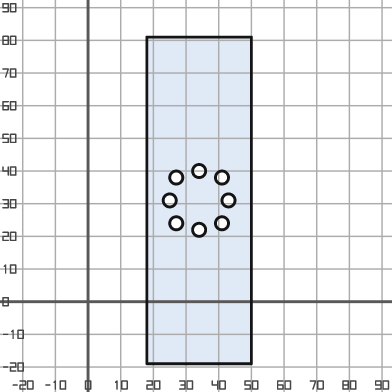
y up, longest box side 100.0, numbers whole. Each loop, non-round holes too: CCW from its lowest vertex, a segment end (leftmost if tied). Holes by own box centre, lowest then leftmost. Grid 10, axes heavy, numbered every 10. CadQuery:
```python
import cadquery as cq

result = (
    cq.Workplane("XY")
    .moveTo(18.0, -19.0)
    .lineTo(50.0, -19.0)
    .lineTo(50.0, 81.0)
    .lineTo(18.0, 81.0)
    .close()
    .moveTo(34.0, 22.0)
    .circle(2.0)
    .moveTo(27.0, 24.0)
    .circle(2.0)
    .moveTo(41.0, 24.0)
    .circle(2.0)
    .moveTo(25.0, 31.0)
    .circle(2.0)
    .moveTo(43.0, 31.0)
    .circle(2.0)
    .moveTo(27.0, 38.0)
    .circle(2.0)
    .moveTo(41.0, 38.0)
    .circle(2.0)
    .moveTo(34.0, 40.0)
    .circle(2.0)
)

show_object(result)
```